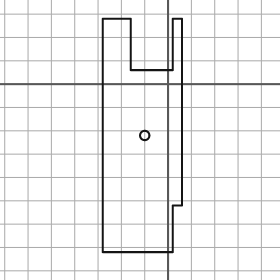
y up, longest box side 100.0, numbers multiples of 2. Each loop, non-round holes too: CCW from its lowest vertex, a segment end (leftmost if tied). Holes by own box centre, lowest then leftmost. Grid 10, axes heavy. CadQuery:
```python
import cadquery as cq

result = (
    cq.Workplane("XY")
    .moveTo(-28.0, -72.0)
    .lineTo(2.0, -72.0)
    .lineTo(2.0, -52.0)
    .lineTo(6.0, -52.0)
    .lineTo(6.0, 28.0)
    .lineTo(2.0, 28.0)
    .lineTo(2.0, 6.0)
    .lineTo(-16.0, 6.0)
    .lineTo(-16.0, 28.0)
    .lineTo(-28.0, 28.0)
    .close()
    .moveTo(-10.0, -22.0)
    .circle(2.0)
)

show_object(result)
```